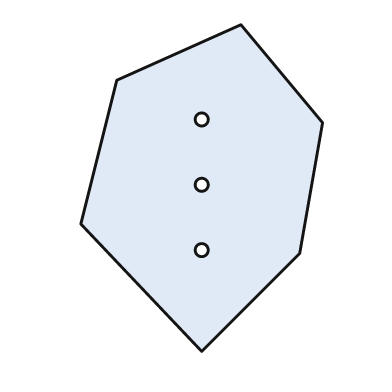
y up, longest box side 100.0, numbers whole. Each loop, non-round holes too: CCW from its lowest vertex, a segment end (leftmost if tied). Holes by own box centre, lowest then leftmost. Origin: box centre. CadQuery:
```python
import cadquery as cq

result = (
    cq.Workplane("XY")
    .moveTo(0.0, -50.0)
    .lineTo(30.0, -20.0)
    .lineTo(37.0, 20.0)
    .lineTo(12.0, 50.0)
    .lineTo(-26.0, 33.0)
    .lineTo(-37.0, -11.0)
    .close()
    .moveTo(0.0, -19.0)
    .circle(2.0)
    .moveTo(0.0, 1.0)
    .circle(2.0)
    .moveTo(0.0, 21.0)
    .circle(2.0)
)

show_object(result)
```